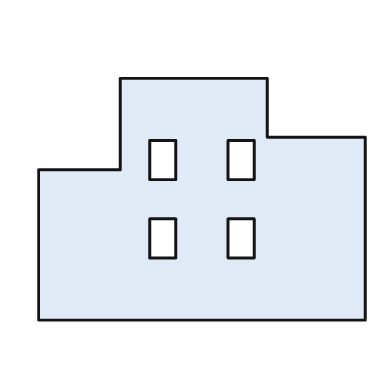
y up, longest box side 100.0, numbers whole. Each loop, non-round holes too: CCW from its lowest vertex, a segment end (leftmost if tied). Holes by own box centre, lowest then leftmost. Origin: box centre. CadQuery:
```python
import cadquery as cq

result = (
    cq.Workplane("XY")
    .moveTo(-50.0, -37.0)
    .lineTo(50.0, -37.0)
    .lineTo(50.0, 19.0)
    .lineTo(20.0, 19.0)
    .lineTo(20.0, 37.0)
    .lineTo(-25.0, 37.0)
    .lineTo(-25.0, 9.0)
    .lineTo(-50.0, 9.0)
    .close()
    .moveTo(-16.0, -18.0)
    .lineTo(-8.0, -18.0)
    .lineTo(-8.0, -6.0)
    .lineTo(-16.0, -6.0)
    .close()
    .moveTo(8.0, -18.0)
    .lineTo(16.0, -18.0)
    .lineTo(16.0, -6.0)
    .lineTo(8.0, -6.0)
    .close()
    .moveTo(-16.0, 6.0)
    .lineTo(-8.0, 6.0)
    .lineTo(-8.0, 18.0)
    .lineTo(-16.0, 18.0)
    .close()
    .moveTo(8.0, 6.0)
    .lineTo(16.0, 6.0)
    .lineTo(16.0, 18.0)
    .lineTo(8.0, 18.0)
    .close()
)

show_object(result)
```